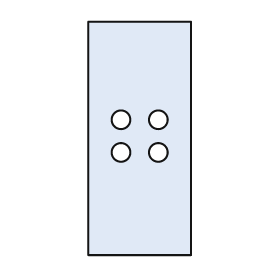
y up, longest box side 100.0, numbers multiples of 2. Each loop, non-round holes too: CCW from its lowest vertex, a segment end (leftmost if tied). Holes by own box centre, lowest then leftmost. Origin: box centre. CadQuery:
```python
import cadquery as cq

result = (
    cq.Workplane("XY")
    .moveTo(-22.0, -50.0)
    .lineTo(22.0, -50.0)
    .lineTo(22.0, 50.0)
    .lineTo(-22.0, 50.0)
    .close()
    .moveTo(-8.0, -6.0)
    .circle(4.0)
    .moveTo(8.0, -6.0)
    .circle(4.0)
    .moveTo(-8.0, 8.0)
    .circle(4.0)
    .moveTo(8.0, 8.0)
    .circle(4.0)
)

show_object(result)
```